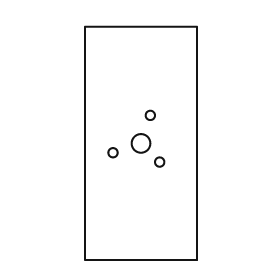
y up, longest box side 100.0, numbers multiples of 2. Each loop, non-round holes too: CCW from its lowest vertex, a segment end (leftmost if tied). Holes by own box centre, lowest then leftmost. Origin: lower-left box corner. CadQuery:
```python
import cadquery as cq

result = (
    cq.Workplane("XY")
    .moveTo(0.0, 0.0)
    .lineTo(48.0, 0.0)
    .lineTo(48.0, 100.0)
    .lineTo(0.0, 100.0)
    .close()
    .moveTo(32.0, 42.0)
    .circle(2.0)
    .moveTo(12.0, 46.0)
    .circle(2.0)
    .moveTo(24.0, 50.0)
    .circle(4.0)
    .moveTo(28.0, 62.0)
    .circle(2.0)
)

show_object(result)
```